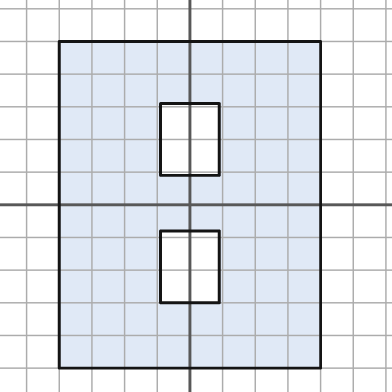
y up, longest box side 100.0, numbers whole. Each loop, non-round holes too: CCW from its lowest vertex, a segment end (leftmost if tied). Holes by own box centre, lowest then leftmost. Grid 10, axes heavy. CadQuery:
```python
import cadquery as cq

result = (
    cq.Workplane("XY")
    .moveTo(-40.0, -50.0)
    .lineTo(40.0, -50.0)
    .lineTo(40.0, 50.0)
    .lineTo(-40.0, 50.0)
    .close()
    .moveTo(-9.0, -30.0)
    .lineTo(9.0, -30.0)
    .lineTo(9.0, -8.0)
    .lineTo(-9.0, -8.0)
    .close()
    .moveTo(-9.0, 9.0)
    .lineTo(9.0, 9.0)
    .lineTo(9.0, 31.0)
    .lineTo(-9.0, 31.0)
    .close()
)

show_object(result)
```